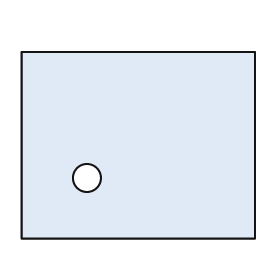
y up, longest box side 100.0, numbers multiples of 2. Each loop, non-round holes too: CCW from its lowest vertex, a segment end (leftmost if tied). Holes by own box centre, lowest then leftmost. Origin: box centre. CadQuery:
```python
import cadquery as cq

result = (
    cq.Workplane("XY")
    .moveTo(-50.0, -40.0)
    .lineTo(50.0, -40.0)
    .lineTo(50.0, 40.0)
    .lineTo(-50.0, 40.0)
    .close()
    .moveTo(-22.0, -14.0)
    .circle(6.0)
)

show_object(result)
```